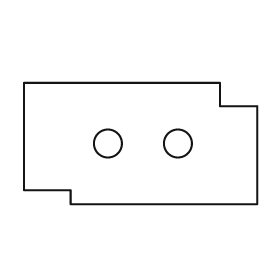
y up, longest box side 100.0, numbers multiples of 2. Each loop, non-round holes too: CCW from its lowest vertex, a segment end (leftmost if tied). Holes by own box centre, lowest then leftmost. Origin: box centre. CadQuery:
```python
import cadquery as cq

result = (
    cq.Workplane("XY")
    .moveTo(-30.0, -26.0)
    .lineTo(50.0, -26.0)
    .lineTo(50.0, 16.0)
    .lineTo(34.0, 16.0)
    .lineTo(34.0, 26.0)
    .lineTo(-50.0, 26.0)
    .lineTo(-50.0, -20.0)
    .lineTo(-30.0, -20.0)
    .close()
    .moveTo(-14.0, 0.0)
    .circle(6.0)
    .moveTo(16.0, 0.0)
    .circle(6.0)
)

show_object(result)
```